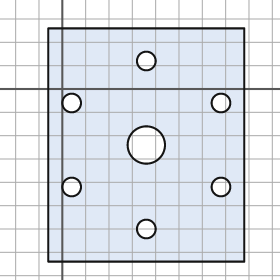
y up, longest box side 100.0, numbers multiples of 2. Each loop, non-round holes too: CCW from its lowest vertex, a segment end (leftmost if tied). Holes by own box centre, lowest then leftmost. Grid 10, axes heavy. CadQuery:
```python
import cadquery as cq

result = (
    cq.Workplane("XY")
    .moveTo(-6.0, -74.0)
    .lineTo(78.0, -74.0)
    .lineTo(78.0, 26.0)
    .lineTo(-6.0, 26.0)
    .close()
    .moveTo(36.0, -60.0)
    .circle(4.0)
    .moveTo(4.0, -42.0)
    .circle(4.0)
    .moveTo(68.0, -42.0)
    .circle(4.0)
    .moveTo(36.0, -24.0)
    .circle(8.0)
    .moveTo(4.0, -6.0)
    .circle(4.0)
    .moveTo(68.0, -6.0)
    .circle(4.0)
    .moveTo(36.0, 12.0)
    .circle(4.0)
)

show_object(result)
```